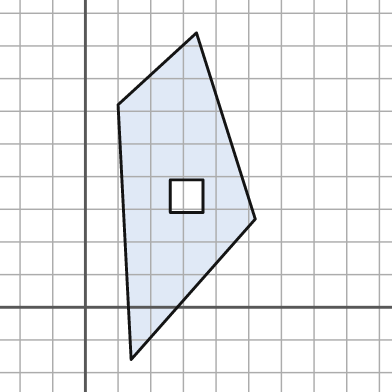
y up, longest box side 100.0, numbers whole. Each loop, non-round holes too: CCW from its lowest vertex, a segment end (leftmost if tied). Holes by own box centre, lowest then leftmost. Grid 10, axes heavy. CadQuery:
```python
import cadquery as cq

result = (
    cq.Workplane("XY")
    .moveTo(14.0, -16.0)
    .lineTo(52.0, 27.0)
    .lineTo(34.0, 84.0)
    .lineTo(10.0, 62.0)
    .close()
    .moveTo(26.0, 29.0)
    .lineTo(36.0, 29.0)
    .lineTo(36.0, 39.0)
    .lineTo(26.0, 39.0)
    .close()
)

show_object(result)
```